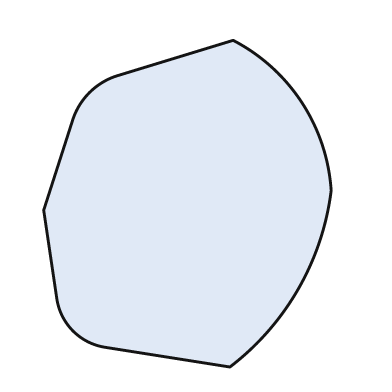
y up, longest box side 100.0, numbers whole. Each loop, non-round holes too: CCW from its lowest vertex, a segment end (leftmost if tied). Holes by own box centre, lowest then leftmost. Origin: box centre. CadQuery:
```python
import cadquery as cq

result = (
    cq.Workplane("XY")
    .moveTo(13.0, -50.0)
    .threePointArc((34.0, -26.0), (44.0, 4.0))
    .threePointArc((35.0, 31.0), (14.0, 50.0))
    .lineTo(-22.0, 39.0)
    .threePointArc((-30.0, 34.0), (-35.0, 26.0))
    .lineTo(-44.0, -2.0)
    .lineTo(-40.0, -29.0)
    .threePointArc((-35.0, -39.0), (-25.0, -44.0))
    .close()
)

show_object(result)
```